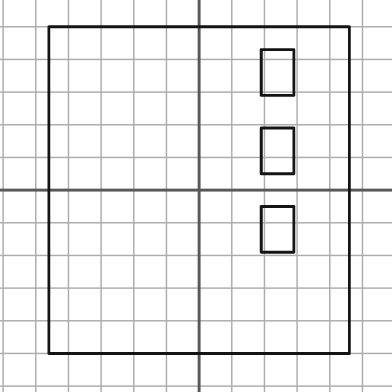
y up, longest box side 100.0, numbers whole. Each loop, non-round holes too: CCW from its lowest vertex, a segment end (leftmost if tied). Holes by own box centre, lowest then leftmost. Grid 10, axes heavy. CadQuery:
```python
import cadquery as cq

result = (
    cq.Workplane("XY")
    .moveTo(-46.0, -50.0)
    .lineTo(46.0, -50.0)
    .lineTo(46.0, 50.0)
    .lineTo(-46.0, 50.0)
    .close()
    .moveTo(19.0, -19.0)
    .lineTo(29.0, -19.0)
    .lineTo(29.0, -5.0)
    .lineTo(19.0, -5.0)
    .close()
    .moveTo(19.0, 5.0)
    .lineTo(29.0, 5.0)
    .lineTo(29.0, 19.0)
    .lineTo(19.0, 19.0)
    .close()
    .moveTo(19.0, 29.0)
    .lineTo(29.0, 29.0)
    .lineTo(29.0, 43.0)
    .lineTo(19.0, 43.0)
    .close()
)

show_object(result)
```